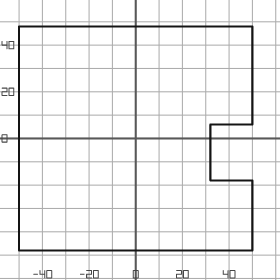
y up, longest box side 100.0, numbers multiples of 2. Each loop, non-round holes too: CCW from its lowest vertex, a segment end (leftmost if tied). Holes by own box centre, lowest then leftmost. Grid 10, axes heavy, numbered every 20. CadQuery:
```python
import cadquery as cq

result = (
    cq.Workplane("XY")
    .moveTo(-50.0, -48.0)
    .lineTo(50.0, -48.0)
    .lineTo(50.0, -18.0)
    .lineTo(32.0, -18.0)
    .lineTo(32.0, 6.0)
    .lineTo(50.0, 6.0)
    .lineTo(50.0, 48.0)
    .lineTo(-50.0, 48.0)
    .close()
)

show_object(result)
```